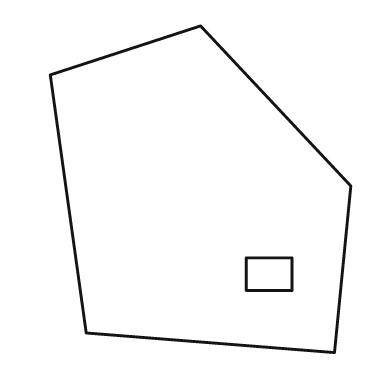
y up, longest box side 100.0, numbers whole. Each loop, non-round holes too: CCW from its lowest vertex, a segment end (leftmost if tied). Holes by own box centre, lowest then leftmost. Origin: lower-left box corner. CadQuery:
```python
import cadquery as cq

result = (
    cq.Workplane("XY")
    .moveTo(87.0, 0.0)
    .lineTo(92.0, 51.0)
    .lineTo(46.0, 100.0)
    .lineTo(0.0, 85.0)
    .lineTo(11.0, 6.0)
    .close()
    .moveTo(60.0, 19.0)
    .lineTo(74.0, 19.0)
    .lineTo(74.0, 29.0)
    .lineTo(60.0, 29.0)
    .close()
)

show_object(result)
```